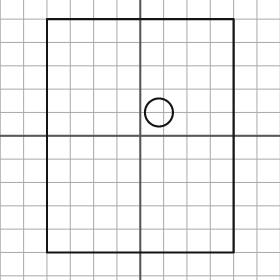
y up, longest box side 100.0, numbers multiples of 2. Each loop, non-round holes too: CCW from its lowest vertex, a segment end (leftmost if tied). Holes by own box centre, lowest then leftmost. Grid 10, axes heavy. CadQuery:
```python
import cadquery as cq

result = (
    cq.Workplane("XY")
    .moveTo(-40.0, -50.0)
    .lineTo(40.0, -50.0)
    .lineTo(40.0, 50.0)
    .lineTo(-40.0, 50.0)
    .close()
    .moveTo(8.0, 10.0)
    .circle(6.0)
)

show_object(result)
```